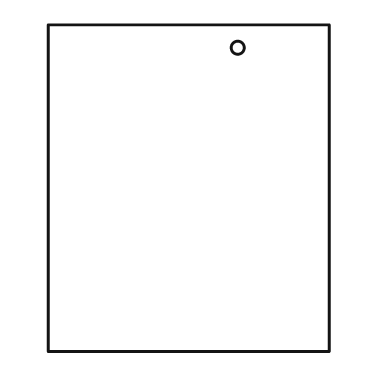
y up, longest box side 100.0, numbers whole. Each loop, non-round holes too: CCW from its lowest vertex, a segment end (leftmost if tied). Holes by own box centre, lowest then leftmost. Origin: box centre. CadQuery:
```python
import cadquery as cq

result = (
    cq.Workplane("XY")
    .moveTo(-43.0, -50.0)
    .lineTo(43.0, -50.0)
    .lineTo(43.0, 50.0)
    .lineTo(-43.0, 50.0)
    .close()
    .moveTo(15.0, 43.0)
    .circle(2.0)
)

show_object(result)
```